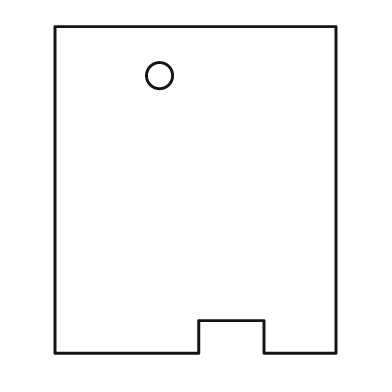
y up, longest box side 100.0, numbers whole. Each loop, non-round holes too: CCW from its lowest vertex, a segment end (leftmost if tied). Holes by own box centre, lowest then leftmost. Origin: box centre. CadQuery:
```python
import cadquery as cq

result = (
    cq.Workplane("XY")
    .moveTo(-43.0, -50.0)
    .lineTo(1.0, -50.0)
    .lineTo(1.0, -40.0)
    .lineTo(21.0, -40.0)
    .lineTo(21.0, -50.0)
    .lineTo(43.0, -50.0)
    .lineTo(43.0, 50.0)
    .lineTo(-43.0, 50.0)
    .close()
    .moveTo(-11.0, 35.0)
    .circle(4.0)
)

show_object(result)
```